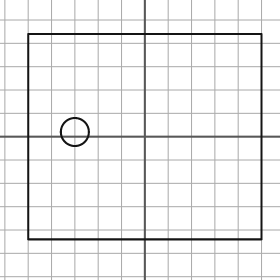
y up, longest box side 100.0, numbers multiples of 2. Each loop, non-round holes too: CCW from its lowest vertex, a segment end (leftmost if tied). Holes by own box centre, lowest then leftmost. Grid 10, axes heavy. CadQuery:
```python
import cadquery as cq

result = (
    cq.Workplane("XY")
    .moveTo(-50.0, -44.0)
    .lineTo(50.0, -44.0)
    .lineTo(50.0, 44.0)
    .lineTo(-50.0, 44.0)
    .close()
    .moveTo(-30.0, 2.0)
    .circle(6.0)
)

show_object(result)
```